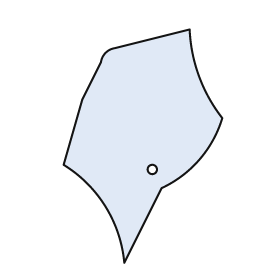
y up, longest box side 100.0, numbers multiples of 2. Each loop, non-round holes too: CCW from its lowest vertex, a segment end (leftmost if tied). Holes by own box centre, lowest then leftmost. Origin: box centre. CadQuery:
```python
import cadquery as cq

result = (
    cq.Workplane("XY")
    .moveTo(-8.0, -50.0)
    .lineTo(8.0, -18.0)
    .threePointArc((24.0, -6.0), (34.0, 12.0))
    .threePointArc((24.0, 30.0), (20.0, 50.0))
    .lineTo(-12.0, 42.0)
    .threePointArc((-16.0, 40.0), (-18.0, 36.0))
    .lineTo(-26.0, 20.0)
    .lineTo(-34.0, -8.0)
    .threePointArc((-16.0, -26.0), (-8.0, -50.0))
    .close()
    .moveTo(4.0, -10.0)
    .circle(2.0)
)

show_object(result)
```